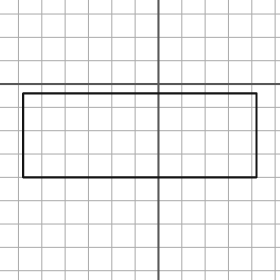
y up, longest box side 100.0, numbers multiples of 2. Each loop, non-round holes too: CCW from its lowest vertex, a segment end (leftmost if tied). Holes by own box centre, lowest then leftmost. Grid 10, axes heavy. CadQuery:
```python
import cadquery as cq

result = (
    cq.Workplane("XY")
    .moveTo(-58.0, -40.0)
    .lineTo(42.0, -40.0)
    .lineTo(42.0, -4.0)
    .lineTo(-58.0, -4.0)
    .close()
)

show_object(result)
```